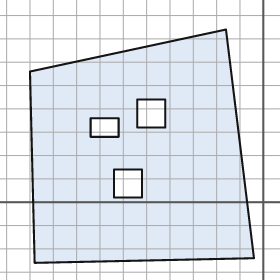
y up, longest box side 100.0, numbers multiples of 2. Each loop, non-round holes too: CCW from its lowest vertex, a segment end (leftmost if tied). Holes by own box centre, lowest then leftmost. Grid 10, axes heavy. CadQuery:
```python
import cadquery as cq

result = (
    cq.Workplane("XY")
    .moveTo(-98.0, -26.0)
    .lineTo(-4.0, -24.0)
    .lineTo(-16.0, 74.0)
    .lineTo(-100.0, 56.0)
    .close()
    .moveTo(-64.0, 2.0)
    .lineTo(-52.0, 2.0)
    .lineTo(-52.0, 14.0)
    .lineTo(-64.0, 14.0)
    .close()
    .moveTo(-74.0, 28.0)
    .lineTo(-62.0, 28.0)
    .lineTo(-62.0, 36.0)
    .lineTo(-74.0, 36.0)
    .close()
    .moveTo(-54.0, 32.0)
    .lineTo(-42.0, 32.0)
    .lineTo(-42.0, 44.0)
    .lineTo(-54.0, 44.0)
    .close()
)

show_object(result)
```